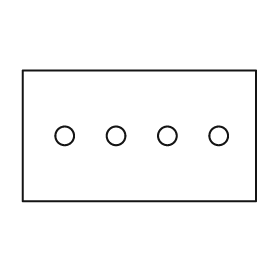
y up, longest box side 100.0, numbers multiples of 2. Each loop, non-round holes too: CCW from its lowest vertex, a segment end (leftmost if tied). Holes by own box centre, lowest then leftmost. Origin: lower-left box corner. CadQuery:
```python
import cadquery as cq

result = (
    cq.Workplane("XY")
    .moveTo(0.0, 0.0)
    .lineTo(100.0, 0.0)
    .lineTo(100.0, 56.0)
    .lineTo(0.0, 56.0)
    .close()
    .moveTo(18.0, 28.0)
    .circle(4.0)
    .moveTo(40.0, 28.0)
    .circle(4.0)
    .moveTo(62.0, 28.0)
    .circle(4.0)
    .moveTo(84.0, 28.0)
    .circle(4.0)
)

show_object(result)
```